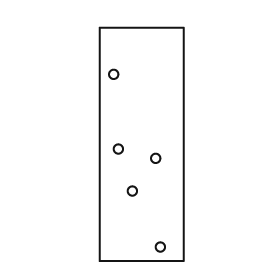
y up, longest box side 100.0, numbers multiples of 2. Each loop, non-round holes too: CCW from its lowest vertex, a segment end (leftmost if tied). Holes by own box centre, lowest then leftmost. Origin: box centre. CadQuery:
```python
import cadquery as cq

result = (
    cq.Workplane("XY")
    .moveTo(-18.0, -50.0)
    .lineTo(18.0, -50.0)
    .lineTo(18.0, 50.0)
    .lineTo(-18.0, 50.0)
    .close()
    .moveTo(8.0, -44.0)
    .circle(2.0)
    .moveTo(-4.0, -20.0)
    .circle(2.0)
    .moveTo(6.0, -6.0)
    .circle(2.0)
    .moveTo(-10.0, -2.0)
    .circle(2.0)
    .moveTo(-12.0, 30.0)
    .circle(2.0)
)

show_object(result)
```